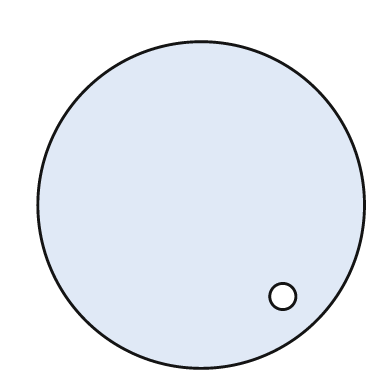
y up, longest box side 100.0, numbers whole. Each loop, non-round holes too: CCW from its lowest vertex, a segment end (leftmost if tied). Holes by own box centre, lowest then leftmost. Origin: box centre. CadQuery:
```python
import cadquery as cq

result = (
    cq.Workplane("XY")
    .moveTo(0.0, 0.0)
    .circle(50.0)
    .moveTo(25.0, -28.0)
    .circle(4.0)
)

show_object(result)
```